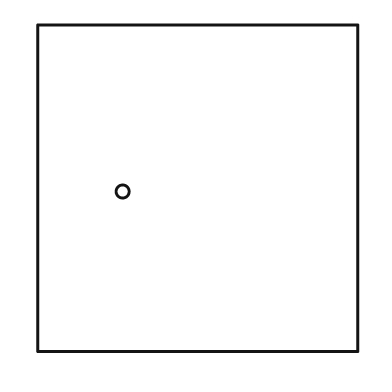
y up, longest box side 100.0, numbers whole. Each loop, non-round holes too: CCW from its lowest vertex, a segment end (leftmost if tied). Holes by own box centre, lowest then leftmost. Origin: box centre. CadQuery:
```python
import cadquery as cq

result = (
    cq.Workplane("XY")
    .moveTo(-49.0, -50.0)
    .lineTo(49.0, -50.0)
    .lineTo(49.0, 50.0)
    .lineTo(-49.0, 50.0)
    .close()
    .moveTo(-23.0, -1.0)
    .circle(2.0)
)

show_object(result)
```